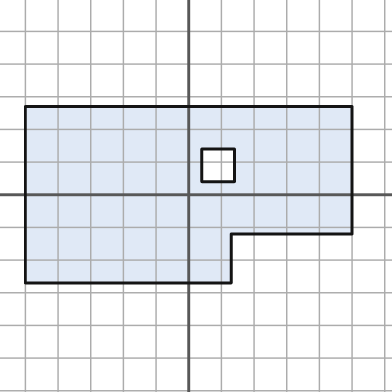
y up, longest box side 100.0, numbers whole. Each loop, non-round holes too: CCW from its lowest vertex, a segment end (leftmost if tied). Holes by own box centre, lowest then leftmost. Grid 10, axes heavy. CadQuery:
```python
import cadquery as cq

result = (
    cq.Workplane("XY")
    .moveTo(-50.0, -27.0)
    .lineTo(13.0, -27.0)
    .lineTo(13.0, -12.0)
    .lineTo(50.0, -12.0)
    .lineTo(50.0, 27.0)
    .lineTo(-50.0, 27.0)
    .close()
    .moveTo(4.0, 4.0)
    .lineTo(14.0, 4.0)
    .lineTo(14.0, 14.0)
    .lineTo(4.0, 14.0)
    .close()
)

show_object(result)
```